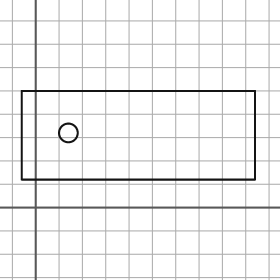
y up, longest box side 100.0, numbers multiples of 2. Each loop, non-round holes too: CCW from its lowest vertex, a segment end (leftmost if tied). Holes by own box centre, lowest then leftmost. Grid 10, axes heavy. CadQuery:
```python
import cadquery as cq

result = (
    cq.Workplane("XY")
    .moveTo(-6.0, 12.0)
    .lineTo(94.0, 12.0)
    .lineTo(94.0, 50.0)
    .lineTo(-6.0, 50.0)
    .close()
    .moveTo(14.0, 32.0)
    .circle(4.0)
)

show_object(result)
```